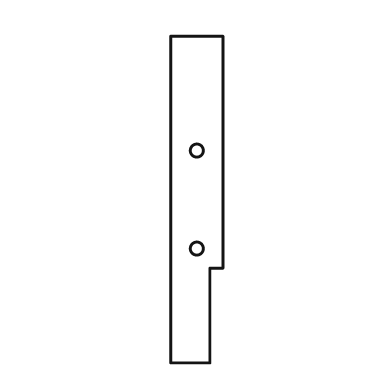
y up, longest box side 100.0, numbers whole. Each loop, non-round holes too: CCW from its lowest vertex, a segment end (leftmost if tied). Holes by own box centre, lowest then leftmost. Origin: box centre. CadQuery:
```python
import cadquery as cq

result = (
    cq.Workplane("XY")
    .moveTo(-8.0, -50.0)
    .lineTo(4.0, -50.0)
    .lineTo(4.0, -21.0)
    .lineTo(8.0, -21.0)
    .lineTo(8.0, 50.0)
    .lineTo(-8.0, 50.0)
    .close()
    .moveTo(0.0, -15.0)
    .circle(2.0)
    .moveTo(0.0, 15.0)
    .circle(2.0)
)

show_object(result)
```